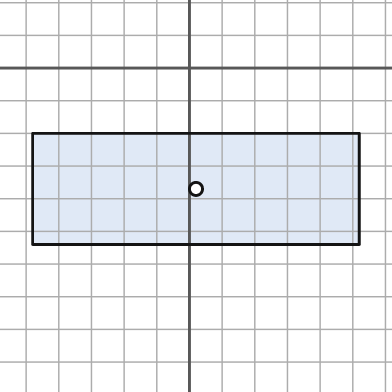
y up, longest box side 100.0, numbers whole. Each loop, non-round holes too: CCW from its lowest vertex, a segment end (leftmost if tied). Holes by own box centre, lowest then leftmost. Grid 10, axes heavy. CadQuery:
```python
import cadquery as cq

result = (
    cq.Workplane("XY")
    .moveTo(-48.0, -54.0)
    .lineTo(52.0, -54.0)
    .lineTo(52.0, -20.0)
    .lineTo(-48.0, -20.0)
    .close()
    .moveTo(2.0, -37.0)
    .circle(2.0)
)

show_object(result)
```